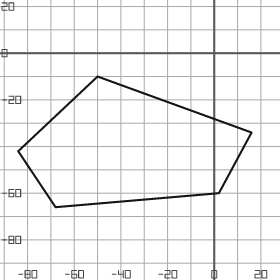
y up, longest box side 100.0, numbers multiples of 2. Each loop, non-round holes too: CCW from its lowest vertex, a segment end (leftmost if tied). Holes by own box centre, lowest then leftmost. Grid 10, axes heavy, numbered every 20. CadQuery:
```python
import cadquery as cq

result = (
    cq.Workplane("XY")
    .moveTo(-68.0, -66.0)
    .lineTo(2.0, -60.0)
    .lineTo(16.0, -34.0)
    .lineTo(-50.0, -10.0)
    .lineTo(-84.0, -42.0)
    .close()
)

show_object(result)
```